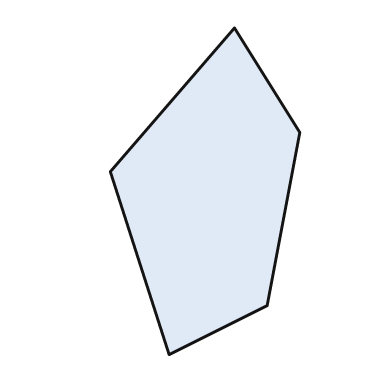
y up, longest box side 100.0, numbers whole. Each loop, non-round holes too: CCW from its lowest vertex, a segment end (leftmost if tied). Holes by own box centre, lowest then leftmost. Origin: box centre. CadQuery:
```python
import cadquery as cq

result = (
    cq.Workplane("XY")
    .moveTo(-11.0, -50.0)
    .lineTo(19.0, -35.0)
    .lineTo(29.0, 18.0)
    .lineTo(9.0, 50.0)
    .lineTo(-29.0, 6.0)
    .close()
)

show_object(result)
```